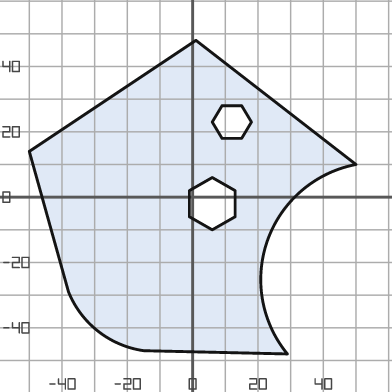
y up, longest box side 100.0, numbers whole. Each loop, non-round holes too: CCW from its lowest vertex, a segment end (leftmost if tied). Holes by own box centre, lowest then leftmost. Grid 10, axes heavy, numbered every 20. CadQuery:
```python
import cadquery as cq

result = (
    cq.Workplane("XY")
    .moveTo(29.0, -48.0)
    .threePointArc((23.0, -13.0), (50.0, 10.0))
    .lineTo(1.0, 48.0)
    .lineTo(-50.0, 14.0)
    .lineTo(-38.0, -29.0)
    .threePointArc((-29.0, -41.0), (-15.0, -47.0))
    .close()
    .moveTo(6.0, -10.0)
    .lineTo(13.0, -6.0)
    .lineTo(13.0, 2.0)
    .lineTo(6.0, 6.0)
    .lineTo(-1.0, 2.0)
    .lineTo(-1.0, -6.0)
    .close()
    .moveTo(9.0, 18.0)
    .lineTo(15.0, 18.0)
    .lineTo(18.0, 23.0)
    .lineTo(15.0, 28.0)
    .lineTo(9.0, 28.0)
    .lineTo(6.0, 23.0)
    .close()
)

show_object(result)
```